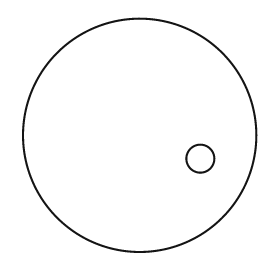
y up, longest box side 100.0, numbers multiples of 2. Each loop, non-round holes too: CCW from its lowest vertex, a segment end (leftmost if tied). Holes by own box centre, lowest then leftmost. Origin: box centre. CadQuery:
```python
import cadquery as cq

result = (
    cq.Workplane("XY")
    .moveTo(0.0, 0.0)
    .circle(50.0)
    .moveTo(26.0, -10.0)
    .circle(6.0)
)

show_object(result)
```